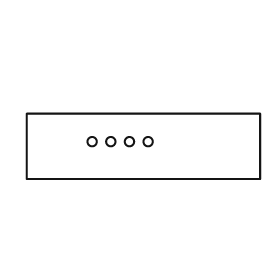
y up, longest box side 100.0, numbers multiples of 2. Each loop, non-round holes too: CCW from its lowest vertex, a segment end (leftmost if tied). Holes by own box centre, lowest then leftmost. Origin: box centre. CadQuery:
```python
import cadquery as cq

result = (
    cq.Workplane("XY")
    .moveTo(-50.0, -14.0)
    .lineTo(50.0, -14.0)
    .lineTo(50.0, 14.0)
    .lineTo(-50.0, 14.0)
    .close()
    .moveTo(-22.0, 2.0)
    .circle(2.0)
    .moveTo(-14.0, 2.0)
    .circle(2.0)
    .moveTo(-6.0, 2.0)
    .circle(2.0)
    .moveTo(2.0, 2.0)
    .circle(2.0)
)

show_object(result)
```